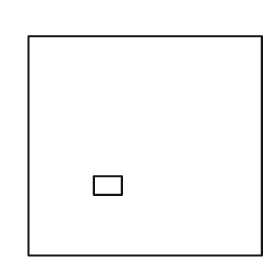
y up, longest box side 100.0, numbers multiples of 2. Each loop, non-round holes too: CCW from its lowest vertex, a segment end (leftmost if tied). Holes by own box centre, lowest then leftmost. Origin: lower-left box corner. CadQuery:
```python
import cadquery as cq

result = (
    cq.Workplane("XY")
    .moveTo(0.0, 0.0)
    .lineTo(100.0, 0.0)
    .lineTo(100.0, 94.0)
    .lineTo(0.0, 94.0)
    .close()
    .moveTo(28.0, 26.0)
    .lineTo(40.0, 26.0)
    .lineTo(40.0, 34.0)
    .lineTo(28.0, 34.0)
    .close()
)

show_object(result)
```